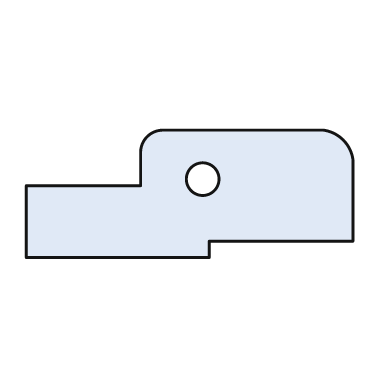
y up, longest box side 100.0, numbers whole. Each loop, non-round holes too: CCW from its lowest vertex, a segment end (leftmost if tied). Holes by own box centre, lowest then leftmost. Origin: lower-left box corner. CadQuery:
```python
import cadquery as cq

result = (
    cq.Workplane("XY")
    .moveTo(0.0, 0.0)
    .lineTo(56.0, 0.0)
    .lineTo(56.0, 5.0)
    .lineTo(100.0, 5.0)
    .lineTo(100.0, 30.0)
    .threePointArc((97.0, 36.0), (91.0, 39.0))
    .lineTo(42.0, 39.0)
    .threePointArc((37.0, 37.0), (35.0, 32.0))
    .lineTo(35.0, 22.0)
    .lineTo(0.0, 22.0)
    .close()
    .moveTo(54.0, 24.0)
    .circle(5.0)
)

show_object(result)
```